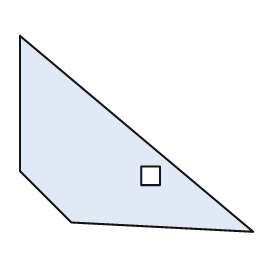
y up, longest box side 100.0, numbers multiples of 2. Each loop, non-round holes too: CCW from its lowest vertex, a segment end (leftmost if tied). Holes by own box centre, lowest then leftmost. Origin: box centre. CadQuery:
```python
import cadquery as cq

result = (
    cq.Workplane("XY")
    .moveTo(50.0, -42.0)
    .lineTo(-50.0, 42.0)
    .lineTo(-50.0, -16.0)
    .lineTo(-28.0, -38.0)
    .close()
    .moveTo(2.0, -22.0)
    .lineTo(10.0, -22.0)
    .lineTo(10.0, -14.0)
    .lineTo(2.0, -14.0)
    .close()
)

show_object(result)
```